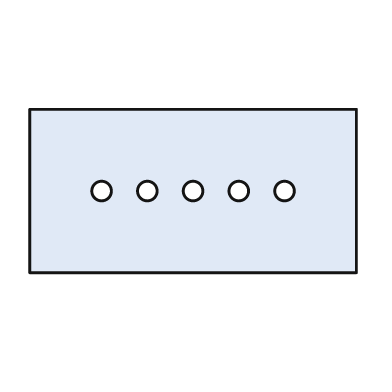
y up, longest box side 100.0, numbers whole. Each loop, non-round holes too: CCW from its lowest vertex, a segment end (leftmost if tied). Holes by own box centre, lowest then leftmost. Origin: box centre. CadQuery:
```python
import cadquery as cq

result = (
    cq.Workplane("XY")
    .moveTo(-50.0, -25.0)
    .lineTo(50.0, -25.0)
    .lineTo(50.0, 25.0)
    .lineTo(-50.0, 25.0)
    .close()
    .moveTo(-28.0, 0.0)
    .circle(3.0)
    .moveTo(-14.0, 0.0)
    .circle(3.0)
    .moveTo(0.0, 0.0)
    .circle(3.0)
    .moveTo(14.0, 0.0)
    .circle(3.0)
    .moveTo(28.0, 0.0)
    .circle(3.0)
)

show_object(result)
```